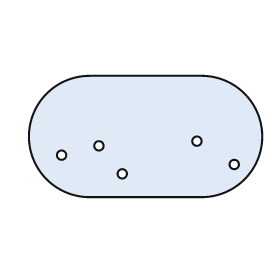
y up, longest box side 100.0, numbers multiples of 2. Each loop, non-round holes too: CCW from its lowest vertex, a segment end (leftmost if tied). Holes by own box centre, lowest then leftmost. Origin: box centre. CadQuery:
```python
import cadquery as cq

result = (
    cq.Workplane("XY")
    .moveTo(-24.0, -26.0)
    .lineTo(24.0, -26.0)
    .threePointArc((50.0, 0.0), (24.0, 26.0))
    .lineTo(-24.0, 26.0)
    .threePointArc((-50.0, 0.0), (-24.0, -26.0))
    .close()
    .moveTo(-10.0, -16.0)
    .circle(2.0)
    .moveTo(38.0, -12.0)
    .circle(2.0)
    .moveTo(-36.0, -8.0)
    .circle(2.0)
    .moveTo(-20.0, -4.0)
    .circle(2.0)
    .moveTo(22.0, -2.0)
    .circle(2.0)
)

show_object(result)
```